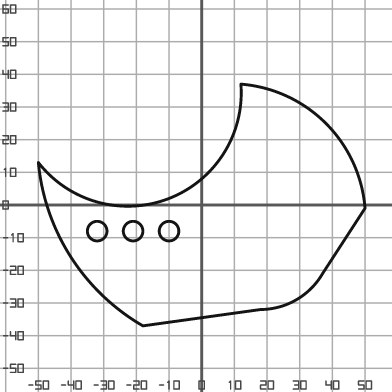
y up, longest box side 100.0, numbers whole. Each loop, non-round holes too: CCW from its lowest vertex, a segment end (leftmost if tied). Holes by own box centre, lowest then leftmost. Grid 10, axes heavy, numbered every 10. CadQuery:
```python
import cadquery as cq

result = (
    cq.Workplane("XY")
    .moveTo(-18.0, -37.0)
    .lineTo(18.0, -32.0)
    .threePointArc((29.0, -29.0), (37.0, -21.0))
    .lineTo(50.0, -1.0)
    .threePointArc((38.0, 25.0), (12.0, 37.0))
    .threePointArc((-10.0, 2.0), (-50.0, 13.0))
    .threePointArc((-40.0, -16.0), (-18.0, -37.0))
    .close()
    .moveTo(-32.0, -8.0)
    .circle(3.0)
    .moveTo(-21.0, -8.0)
    .circle(3.0)
    .moveTo(-10.0, -8.0)
    .circle(3.0)
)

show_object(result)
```